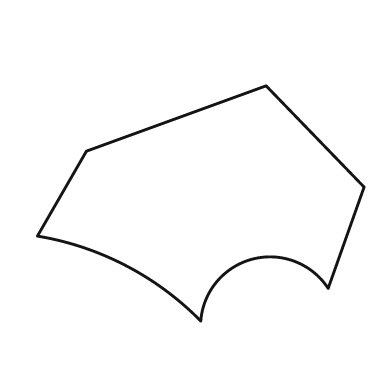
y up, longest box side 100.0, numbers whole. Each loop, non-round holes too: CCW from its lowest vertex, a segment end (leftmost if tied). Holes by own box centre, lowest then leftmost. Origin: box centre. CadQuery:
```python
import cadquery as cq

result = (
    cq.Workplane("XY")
    .moveTo(0.0, -36.0)
    .threePointArc((16.0, -17.0), (39.0, -26.0))
    .lineTo(50.0, 5.0)
    .lineTo(20.0, 36.0)
    .lineTo(-35.0, 16.0)
    .lineTo(-50.0, -10.0)
    .threePointArc((-23.0, -19.0), (0.0, -36.0))
    .close()
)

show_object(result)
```